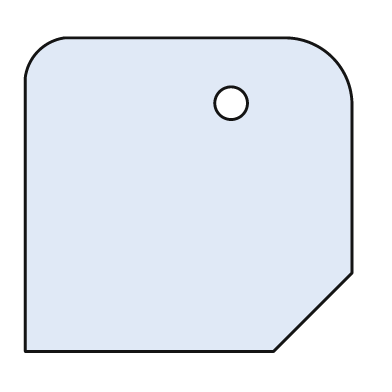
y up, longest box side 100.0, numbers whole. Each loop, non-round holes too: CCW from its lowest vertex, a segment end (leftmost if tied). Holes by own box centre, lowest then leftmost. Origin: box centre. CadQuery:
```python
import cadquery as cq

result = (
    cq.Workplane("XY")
    .moveTo(-50.0, -48.0)
    .lineTo(26.0, -48.0)
    .lineTo(50.0, -24.0)
    .lineTo(50.0, 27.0)
    .threePointArc((44.0, 42.0), (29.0, 48.0))
    .lineTo(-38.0, 48.0)
    .threePointArc((-46.0, 44.0), (-50.0, 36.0))
    .close()
    .moveTo(13.0, 28.0)
    .circle(5.0)
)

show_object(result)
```